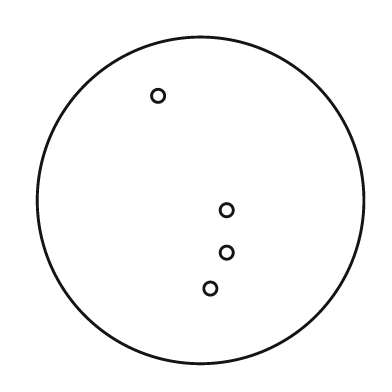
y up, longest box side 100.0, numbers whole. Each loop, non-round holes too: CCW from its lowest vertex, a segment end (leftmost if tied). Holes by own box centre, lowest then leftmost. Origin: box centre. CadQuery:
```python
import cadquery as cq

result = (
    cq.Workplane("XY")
    .moveTo(0.0, 0.0)
    .circle(50.0)
    .moveTo(3.0, -27.0)
    .circle(2.0)
    .moveTo(8.0, -16.0)
    .circle(2.0)
    .moveTo(8.0, -3.0)
    .circle(2.0)
    .moveTo(-13.0, 32.0)
    .circle(2.0)
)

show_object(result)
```